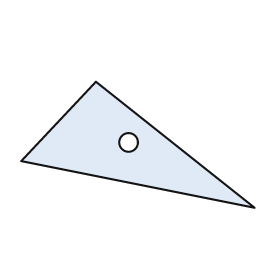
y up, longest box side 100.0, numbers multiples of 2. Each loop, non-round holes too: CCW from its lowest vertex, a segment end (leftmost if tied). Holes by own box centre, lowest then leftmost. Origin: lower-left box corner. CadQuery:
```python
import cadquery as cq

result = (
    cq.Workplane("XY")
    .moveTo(100.0, 0.0)
    .lineTo(32.0, 54.0)
    .lineTo(0.0, 20.0)
    .close()
    .moveTo(46.0, 28.0)
    .circle(4.0)
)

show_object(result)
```